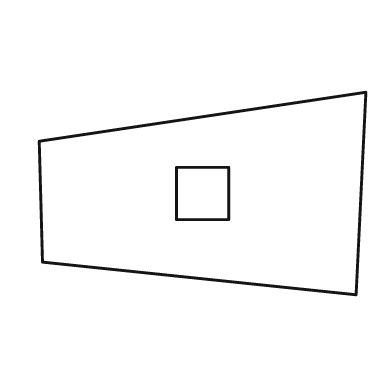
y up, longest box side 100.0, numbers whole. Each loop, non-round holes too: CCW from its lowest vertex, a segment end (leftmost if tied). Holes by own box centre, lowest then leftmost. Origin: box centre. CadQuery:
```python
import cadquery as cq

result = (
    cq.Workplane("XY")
    .moveTo(47.0, -31.0)
    .lineTo(50.0, 31.0)
    .lineTo(-50.0, 16.0)
    .lineTo(-49.0, -21.0)
    .close()
    .moveTo(-8.0, -8.0)
    .lineTo(8.0, -8.0)
    .lineTo(8.0, 8.0)
    .lineTo(-8.0, 8.0)
    .close()
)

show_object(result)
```